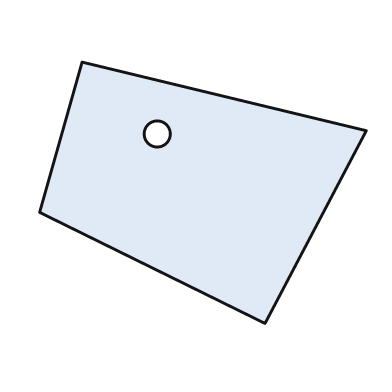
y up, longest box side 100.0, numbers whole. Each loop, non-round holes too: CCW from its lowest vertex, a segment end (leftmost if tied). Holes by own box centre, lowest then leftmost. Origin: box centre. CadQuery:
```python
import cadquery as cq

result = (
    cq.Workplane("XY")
    .moveTo(19.0, -40.0)
    .lineTo(50.0, 19.0)
    .lineTo(-37.0, 40.0)
    .lineTo(-50.0, -6.0)
    .close()
    .moveTo(-14.0, 18.0)
    .circle(4.0)
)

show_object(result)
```